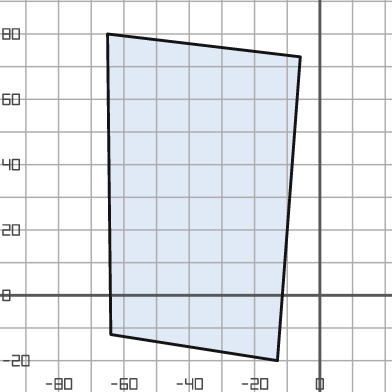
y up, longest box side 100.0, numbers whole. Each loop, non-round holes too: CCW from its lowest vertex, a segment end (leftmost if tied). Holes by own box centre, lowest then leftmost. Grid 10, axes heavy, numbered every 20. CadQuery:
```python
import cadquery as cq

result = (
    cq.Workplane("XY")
    .moveTo(-13.0, -20.0)
    .lineTo(-6.0, 73.0)
    .lineTo(-65.0, 80.0)
    .lineTo(-64.0, -12.0)
    .close()
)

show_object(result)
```